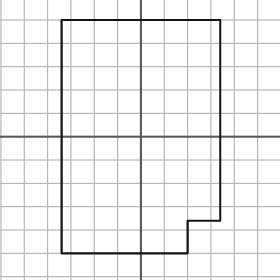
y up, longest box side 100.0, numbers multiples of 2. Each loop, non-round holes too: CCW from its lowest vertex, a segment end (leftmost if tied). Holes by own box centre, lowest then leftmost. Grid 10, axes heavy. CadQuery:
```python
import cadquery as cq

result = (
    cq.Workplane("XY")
    .moveTo(-34.0, -50.0)
    .lineTo(20.0, -50.0)
    .lineTo(20.0, -36.0)
    .lineTo(34.0, -36.0)
    .lineTo(34.0, 50.0)
    .lineTo(-34.0, 50.0)
    .close()
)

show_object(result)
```